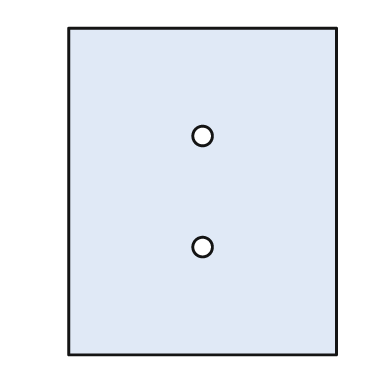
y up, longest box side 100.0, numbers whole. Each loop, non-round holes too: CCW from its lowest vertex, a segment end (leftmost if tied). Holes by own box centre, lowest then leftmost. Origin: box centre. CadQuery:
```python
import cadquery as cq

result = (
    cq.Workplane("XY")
    .moveTo(-41.0, -50.0)
    .lineTo(41.0, -50.0)
    .lineTo(41.0, 50.0)
    .lineTo(-41.0, 50.0)
    .close()
    .moveTo(0.0, -17.0)
    .circle(3.0)
    .moveTo(0.0, 17.0)
    .circle(3.0)
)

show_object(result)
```